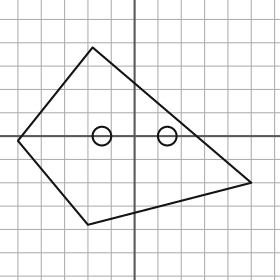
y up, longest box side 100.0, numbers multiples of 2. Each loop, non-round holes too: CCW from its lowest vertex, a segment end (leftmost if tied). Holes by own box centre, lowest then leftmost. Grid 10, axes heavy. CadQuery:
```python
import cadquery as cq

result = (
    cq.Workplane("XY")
    .moveTo(-20.0, -38.0)
    .lineTo(50.0, -20.0)
    .lineTo(-18.0, 38.0)
    .lineTo(-50.0, -2.0)
    .close()
    .moveTo(-14.0, 0.0)
    .circle(4.0)
    .moveTo(14.0, 0.0)
    .circle(4.0)
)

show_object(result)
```